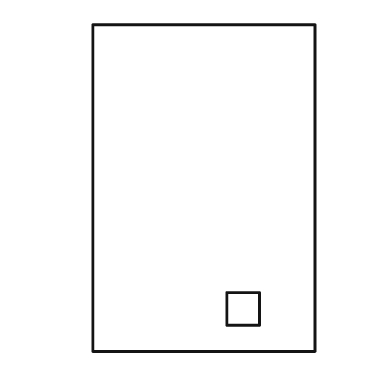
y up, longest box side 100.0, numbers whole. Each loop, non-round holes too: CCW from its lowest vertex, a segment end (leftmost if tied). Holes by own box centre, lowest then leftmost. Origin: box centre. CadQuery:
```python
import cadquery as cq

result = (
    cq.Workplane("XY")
    .moveTo(-34.0, -50.0)
    .lineTo(34.0, -50.0)
    .lineTo(34.0, 50.0)
    .lineTo(-34.0, 50.0)
    .close()
    .moveTo(7.0, -42.0)
    .lineTo(17.0, -42.0)
    .lineTo(17.0, -32.0)
    .lineTo(7.0, -32.0)
    .close()
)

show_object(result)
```